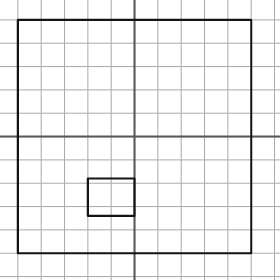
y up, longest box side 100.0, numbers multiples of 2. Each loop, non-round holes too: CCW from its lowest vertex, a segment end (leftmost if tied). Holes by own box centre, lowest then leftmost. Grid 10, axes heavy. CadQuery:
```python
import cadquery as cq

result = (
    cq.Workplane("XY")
    .moveTo(-50.0, -50.0)
    .lineTo(50.0, -50.0)
    .lineTo(50.0, 50.0)
    .lineTo(-50.0, 50.0)
    .close()
    .moveTo(-20.0, -34.0)
    .lineTo(0.0, -34.0)
    .lineTo(0.0, -18.0)
    .lineTo(-20.0, -18.0)
    .close()
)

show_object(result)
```